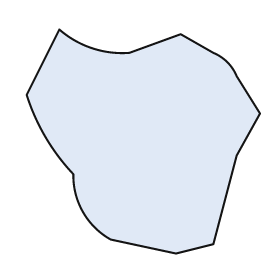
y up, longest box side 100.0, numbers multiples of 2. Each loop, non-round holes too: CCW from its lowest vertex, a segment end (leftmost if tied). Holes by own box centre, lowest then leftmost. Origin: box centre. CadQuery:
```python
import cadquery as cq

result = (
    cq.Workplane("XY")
    .moveTo(14.0, -48.0)
    .lineTo(30.0, -44.0)
    .lineTo(40.0, -6.0)
    .lineTo(50.0, 12.0)
    .lineTo(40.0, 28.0)
    .threePointArc((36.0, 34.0), (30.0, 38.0))
    .lineTo(16.0, 46.0)
    .lineTo(-6.0, 38.0)
    .threePointArc((-22.0, 40.0), (-36.0, 48.0))
    .lineTo(-50.0, 20.0)
    .threePointArc((-42.0, 2.0), (-30.0, -14.0))
    .threePointArc((-26.0, -30.0), (-14.0, -42.0))
    .close()
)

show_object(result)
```